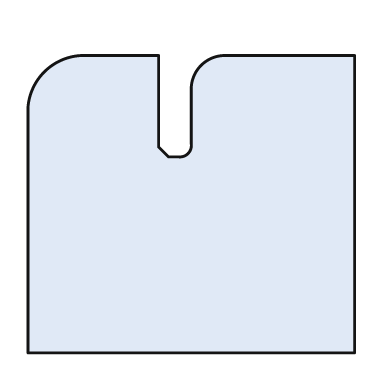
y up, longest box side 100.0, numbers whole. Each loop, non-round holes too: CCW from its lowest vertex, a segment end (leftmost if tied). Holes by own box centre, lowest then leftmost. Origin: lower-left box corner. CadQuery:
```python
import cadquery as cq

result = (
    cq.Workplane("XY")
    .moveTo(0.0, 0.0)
    .lineTo(100.0, 0.0)
    .lineTo(100.0, 91.0)
    .lineTo(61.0, 91.0)
    .threePointArc((53.0, 88.0), (50.0, 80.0))
    .lineTo(50.0, 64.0)
    .threePointArc((49.0, 61.0), (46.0, 60.0))
    .lineTo(43.0, 60.0)
    .lineTo(40.0, 63.0)
    .lineTo(40.0, 91.0)
    .lineTo(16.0, 91.0)
    .threePointArc((5.0, 86.0), (0.0, 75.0))
    .close()
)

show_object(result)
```